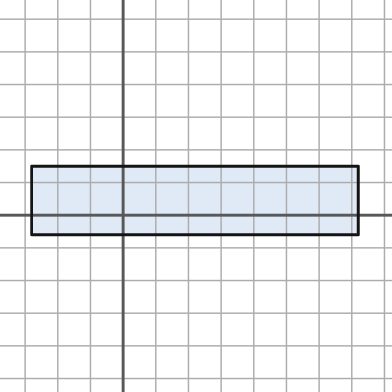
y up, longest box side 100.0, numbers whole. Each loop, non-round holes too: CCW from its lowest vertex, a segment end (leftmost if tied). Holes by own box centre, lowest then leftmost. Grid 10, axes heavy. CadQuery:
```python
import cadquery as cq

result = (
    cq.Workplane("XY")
    .moveTo(-28.0, -6.0)
    .lineTo(72.0, -6.0)
    .lineTo(72.0, 15.0)
    .lineTo(-28.0, 15.0)
    .close()
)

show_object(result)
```